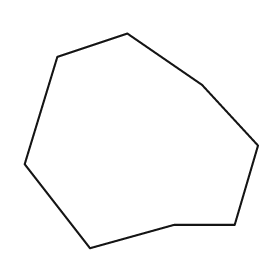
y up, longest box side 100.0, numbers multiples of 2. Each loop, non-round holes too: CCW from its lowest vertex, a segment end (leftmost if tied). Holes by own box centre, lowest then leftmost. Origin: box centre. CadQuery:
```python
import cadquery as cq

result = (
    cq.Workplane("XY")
    .moveTo(-22.0, -46.0)
    .lineTo(14.0, -36.0)
    .lineTo(40.0, -36.0)
    .lineTo(50.0, -2.0)
    .lineTo(26.0, 24.0)
    .lineTo(-6.0, 46.0)
    .lineTo(-36.0, 36.0)
    .lineTo(-50.0, -10.0)
    .close()
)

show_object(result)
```